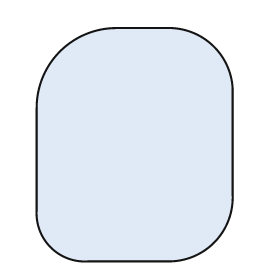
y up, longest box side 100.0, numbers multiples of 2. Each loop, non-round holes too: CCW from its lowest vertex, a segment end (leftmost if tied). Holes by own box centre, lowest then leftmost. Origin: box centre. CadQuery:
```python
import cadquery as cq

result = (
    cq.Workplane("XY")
    .moveTo(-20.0, -50.0)
    .lineTo(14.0, -50.0)
    .threePointArc((34.0, -42.0), (42.0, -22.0))
    .lineTo(42.0, 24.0)
    .threePointArc((34.0, 42.0), (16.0, 50.0))
    .lineTo(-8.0, 50.0)
    .threePointArc((-32.0, 40.0), (-42.0, 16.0))
    .lineTo(-42.0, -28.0)
    .threePointArc((-36.0, -44.0), (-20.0, -50.0))
    .close()
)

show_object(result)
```